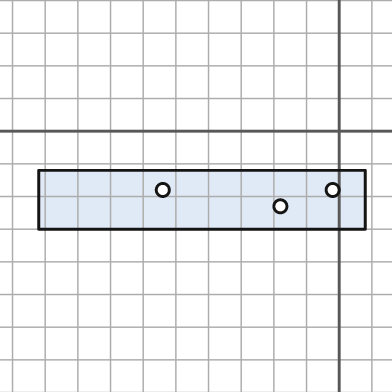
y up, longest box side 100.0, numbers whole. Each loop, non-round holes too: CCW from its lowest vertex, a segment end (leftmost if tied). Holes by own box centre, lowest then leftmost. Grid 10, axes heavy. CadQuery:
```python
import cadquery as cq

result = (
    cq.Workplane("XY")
    .moveTo(-92.0, -30.0)
    .lineTo(8.0, -30.0)
    .lineTo(8.0, -12.0)
    .lineTo(-92.0, -12.0)
    .close()
    .moveTo(-18.0, -23.0)
    .circle(2.0)
    .moveTo(-54.0, -18.0)
    .circle(2.0)
    .moveTo(-2.0, -18.0)
    .circle(2.0)
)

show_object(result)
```